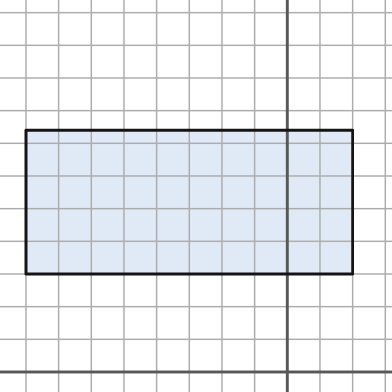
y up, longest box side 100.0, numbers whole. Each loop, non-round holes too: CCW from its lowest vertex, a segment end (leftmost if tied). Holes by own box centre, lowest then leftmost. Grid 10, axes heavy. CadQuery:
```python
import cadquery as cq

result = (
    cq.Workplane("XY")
    .moveTo(-80.0, 30.0)
    .lineTo(20.0, 30.0)
    .lineTo(20.0, 74.0)
    .lineTo(-80.0, 74.0)
    .close()
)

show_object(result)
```